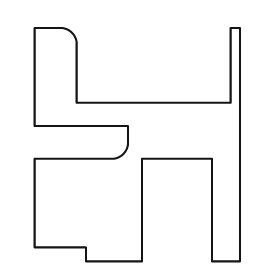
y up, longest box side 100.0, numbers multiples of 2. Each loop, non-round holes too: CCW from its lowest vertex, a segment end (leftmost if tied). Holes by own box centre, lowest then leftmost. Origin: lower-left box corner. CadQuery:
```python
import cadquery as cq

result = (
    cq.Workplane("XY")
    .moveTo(22.0, 0.0)
    .lineTo(46.0, 0.0)
    .lineTo(46.0, 44.0)
    .lineTo(76.0, 44.0)
    .lineTo(76.0, 0.0)
    .lineTo(88.0, 0.0)
    .lineTo(88.0, 100.0)
    .lineTo(84.0, 100.0)
    .lineTo(84.0, 68.0)
    .lineTo(18.0, 68.0)
    .lineTo(18.0, 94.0)
    .threePointArc((16.0, 98.0), (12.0, 100.0))
    .lineTo(0.0, 100.0)
    .lineTo(0.0, 58.0)
    .lineTo(40.0, 58.0)
    .lineTo(40.0, 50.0)
    .threePointArc((38.0, 46.0), (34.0, 44.0))
    .lineTo(0.0, 44.0)
    .lineTo(0.0, 6.0)
    .lineTo(22.0, 6.0)
    .close()
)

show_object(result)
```